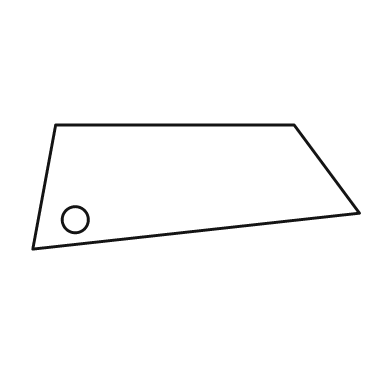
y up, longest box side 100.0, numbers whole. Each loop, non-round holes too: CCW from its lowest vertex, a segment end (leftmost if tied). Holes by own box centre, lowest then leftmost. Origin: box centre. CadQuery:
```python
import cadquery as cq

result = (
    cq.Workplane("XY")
    .moveTo(-50.0, -19.0)
    .lineTo(50.0, -8.0)
    .lineTo(30.0, 19.0)
    .lineTo(-43.0, 19.0)
    .close()
    .moveTo(-37.0, -10.0)
    .circle(4.0)
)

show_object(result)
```